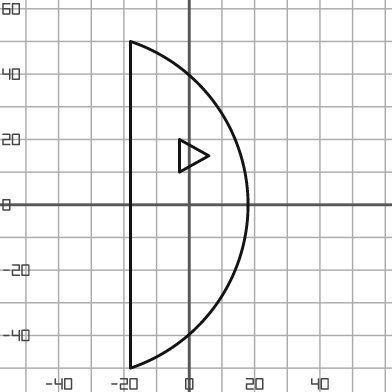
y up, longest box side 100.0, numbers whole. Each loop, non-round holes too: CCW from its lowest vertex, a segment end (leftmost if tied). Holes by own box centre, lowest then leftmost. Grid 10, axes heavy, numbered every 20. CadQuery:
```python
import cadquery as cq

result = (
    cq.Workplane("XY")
    .moveTo(-18.0, -50.0)
    .threePointArc((18.0, 0.0), (-18.0, 50.0))
    .close()
    .moveTo(-3.0, 10.0)
    .lineTo(6.0, 15.0)
    .lineTo(-3.0, 20.0)
    .close()
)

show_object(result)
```